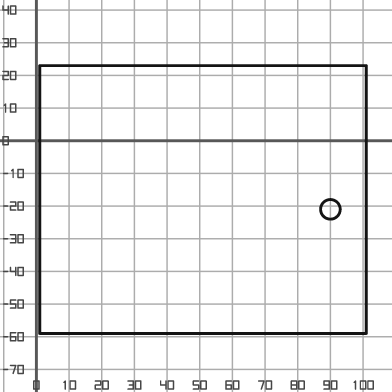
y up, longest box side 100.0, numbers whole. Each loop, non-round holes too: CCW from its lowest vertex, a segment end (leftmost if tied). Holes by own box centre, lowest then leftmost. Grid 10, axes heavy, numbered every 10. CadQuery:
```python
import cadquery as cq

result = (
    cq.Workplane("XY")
    .moveTo(1.0, -59.0)
    .lineTo(101.0, -59.0)
    .lineTo(101.0, 23.0)
    .lineTo(1.0, 23.0)
    .close()
    .moveTo(90.0, -21.0)
    .circle(3.0)
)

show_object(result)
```